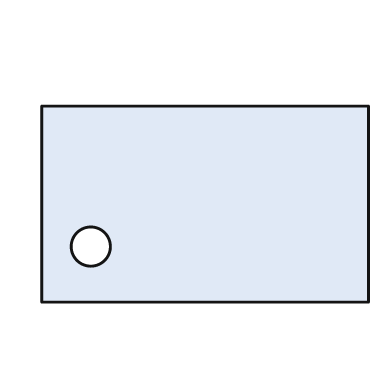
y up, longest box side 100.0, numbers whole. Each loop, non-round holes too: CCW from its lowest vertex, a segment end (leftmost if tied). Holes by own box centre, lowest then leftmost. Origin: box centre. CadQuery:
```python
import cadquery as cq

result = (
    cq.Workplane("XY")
    .moveTo(-50.0, -30.0)
    .lineTo(50.0, -30.0)
    .lineTo(50.0, 30.0)
    .lineTo(-50.0, 30.0)
    .close()
    .moveTo(-35.0, -13.0)
    .circle(6.0)
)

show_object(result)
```